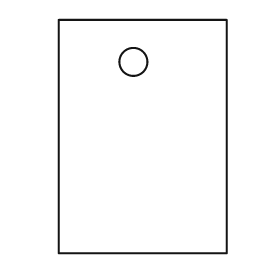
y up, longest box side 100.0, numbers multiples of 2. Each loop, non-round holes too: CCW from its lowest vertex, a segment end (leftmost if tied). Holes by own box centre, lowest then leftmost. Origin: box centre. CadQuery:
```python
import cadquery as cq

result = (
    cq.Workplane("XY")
    .moveTo(-36.0, -50.0)
    .lineTo(36.0, -50.0)
    .lineTo(36.0, 50.0)
    .lineTo(-36.0, 50.0)
    .close()
    .moveTo(-4.0, 32.0)
    .circle(6.0)
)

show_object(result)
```